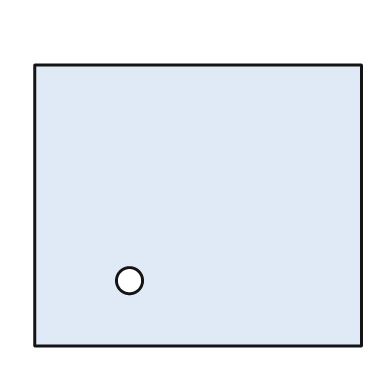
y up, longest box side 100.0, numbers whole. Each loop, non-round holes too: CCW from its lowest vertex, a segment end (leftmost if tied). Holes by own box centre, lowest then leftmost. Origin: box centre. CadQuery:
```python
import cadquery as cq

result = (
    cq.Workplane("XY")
    .moveTo(-50.0, -43.0)
    .lineTo(50.0, -43.0)
    .lineTo(50.0, 43.0)
    .lineTo(-50.0, 43.0)
    .close()
    .moveTo(-21.0, -23.0)
    .circle(4.0)
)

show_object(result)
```